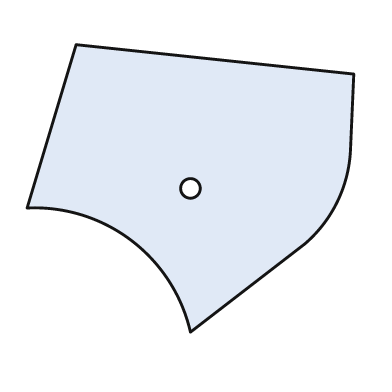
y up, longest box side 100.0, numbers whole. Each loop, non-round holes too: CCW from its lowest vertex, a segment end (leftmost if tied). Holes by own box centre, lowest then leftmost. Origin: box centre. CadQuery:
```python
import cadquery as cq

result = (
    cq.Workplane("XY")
    .moveTo(0.0, -44.0)
    .lineTo(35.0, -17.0)
    .threePointArc((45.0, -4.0), (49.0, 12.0))
    .lineTo(50.0, 35.0)
    .lineTo(-35.0, 44.0)
    .lineTo(-50.0, -6.0)
    .threePointArc((-18.0, -16.0), (0.0, -44.0))
    .close()
    .moveTo(0.0, 0.0)
    .circle(3.0)
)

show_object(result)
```